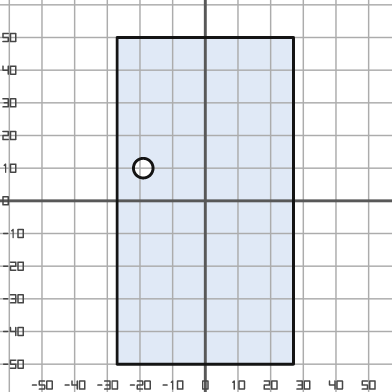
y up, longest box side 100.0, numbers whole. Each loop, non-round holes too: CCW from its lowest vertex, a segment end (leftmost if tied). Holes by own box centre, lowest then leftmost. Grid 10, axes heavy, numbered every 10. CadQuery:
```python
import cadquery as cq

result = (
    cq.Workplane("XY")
    .moveTo(-27.0, -50.0)
    .lineTo(27.0, -50.0)
    .lineTo(27.0, 50.0)
    .lineTo(-27.0, 50.0)
    .close()
    .moveTo(-19.0, 10.0)
    .circle(3.0)
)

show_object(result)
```